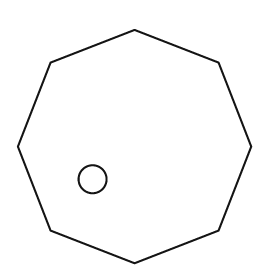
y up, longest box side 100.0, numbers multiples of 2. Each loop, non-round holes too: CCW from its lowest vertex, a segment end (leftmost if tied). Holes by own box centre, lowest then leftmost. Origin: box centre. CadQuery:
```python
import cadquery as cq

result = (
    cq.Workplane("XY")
    .moveTo(0.0, -50.0)
    .lineTo(36.0, -36.0)
    .lineTo(50.0, 0.0)
    .lineTo(36.0, 36.0)
    .lineTo(0.0, 50.0)
    .lineTo(-36.0, 36.0)
    .lineTo(-50.0, 0.0)
    .lineTo(-36.0, -36.0)
    .close()
    .moveTo(-18.0, -14.0)
    .circle(6.0)
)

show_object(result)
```